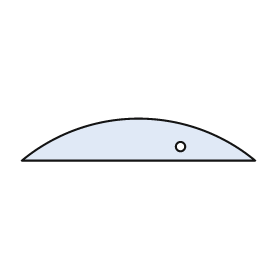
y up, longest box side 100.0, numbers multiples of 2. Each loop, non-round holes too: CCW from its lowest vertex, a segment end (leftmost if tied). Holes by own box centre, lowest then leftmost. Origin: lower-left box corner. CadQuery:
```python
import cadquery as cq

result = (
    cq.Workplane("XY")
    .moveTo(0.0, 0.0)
    .lineTo(100.0, 0.0)
    .threePointArc((50.0, 18.0), (0.0, 0.0))
    .close()
    .moveTo(68.0, 6.0)
    .circle(2.0)
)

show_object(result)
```